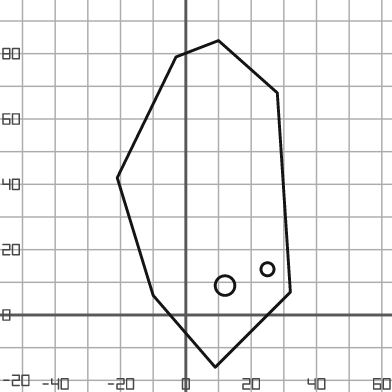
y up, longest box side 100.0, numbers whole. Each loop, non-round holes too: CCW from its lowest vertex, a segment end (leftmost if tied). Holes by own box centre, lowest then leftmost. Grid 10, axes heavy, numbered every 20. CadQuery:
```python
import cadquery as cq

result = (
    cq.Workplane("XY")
    .moveTo(9.0, -16.0)
    .lineTo(32.0, 7.0)
    .lineTo(28.0, 68.0)
    .lineTo(10.0, 84.0)
    .lineTo(-3.0, 79.0)
    .lineTo(-21.0, 42.0)
    .lineTo(-10.0, 6.0)
    .close()
    .moveTo(12.0, 9.0)
    .circle(3.0)
    .moveTo(25.0, 14.0)
    .circle(2.0)
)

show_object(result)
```